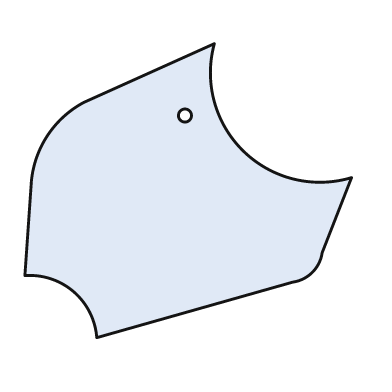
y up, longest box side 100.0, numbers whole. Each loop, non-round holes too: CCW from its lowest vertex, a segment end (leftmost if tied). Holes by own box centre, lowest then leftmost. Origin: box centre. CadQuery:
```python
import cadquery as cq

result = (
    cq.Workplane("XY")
    .moveTo(-28.0, -45.0)
    .lineTo(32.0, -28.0)
    .threePointArc((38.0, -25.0), (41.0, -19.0))
    .lineTo(50.0, 4.0)
    .threePointArc((17.0, 12.0), (8.0, 45.0))
    .lineTo(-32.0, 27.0)
    .threePointArc((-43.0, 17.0), (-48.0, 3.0))
    .lineTo(-50.0, -26.0)
    .threePointArc((-35.0, -31.0), (-28.0, -45.0))
    .close()
    .moveTo(-1.0, 23.0)
    .circle(2.0)
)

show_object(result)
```